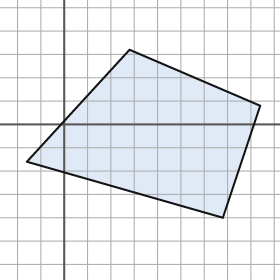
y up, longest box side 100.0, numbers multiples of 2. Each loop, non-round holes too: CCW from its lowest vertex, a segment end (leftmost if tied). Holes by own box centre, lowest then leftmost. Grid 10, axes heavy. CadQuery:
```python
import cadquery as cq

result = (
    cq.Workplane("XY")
    .moveTo(68.0, -40.0)
    .lineTo(84.0, 8.0)
    .lineTo(28.0, 32.0)
    .lineTo(-16.0, -16.0)
    .close()
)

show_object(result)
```